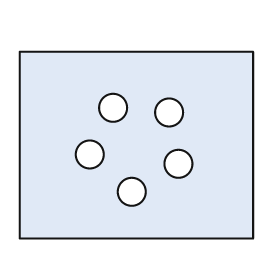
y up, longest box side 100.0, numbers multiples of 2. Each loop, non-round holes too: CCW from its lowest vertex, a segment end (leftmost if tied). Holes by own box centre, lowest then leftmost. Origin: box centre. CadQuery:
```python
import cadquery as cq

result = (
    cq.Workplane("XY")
    .moveTo(-50.0, -40.0)
    .lineTo(50.0, -40.0)
    .lineTo(50.0, 40.0)
    .lineTo(-50.0, 40.0)
    .close()
    .moveTo(-2.0, -20.0)
    .circle(6.0)
    .moveTo(18.0, -8.0)
    .circle(6.0)
    .moveTo(-20.0, -4.0)
    .circle(6.0)
    .moveTo(14.0, 14.0)
    .circle(6.0)
    .moveTo(-10.0, 16.0)
    .circle(6.0)
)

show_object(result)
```